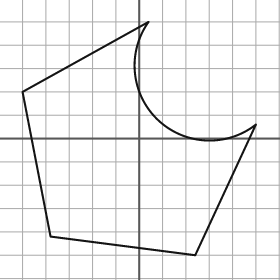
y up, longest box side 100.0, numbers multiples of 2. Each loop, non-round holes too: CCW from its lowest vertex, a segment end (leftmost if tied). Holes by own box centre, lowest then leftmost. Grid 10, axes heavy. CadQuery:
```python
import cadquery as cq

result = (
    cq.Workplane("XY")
    .moveTo(24.0, -50.0)
    .lineTo(50.0, 6.0)
    .threePointArc((8.0, 8.0), (4.0, 50.0))
    .lineTo(-50.0, 20.0)
    .lineTo(-38.0, -42.0)
    .close()
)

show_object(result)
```